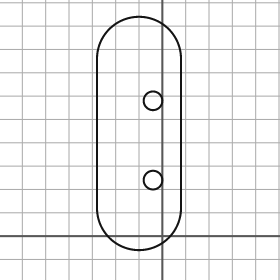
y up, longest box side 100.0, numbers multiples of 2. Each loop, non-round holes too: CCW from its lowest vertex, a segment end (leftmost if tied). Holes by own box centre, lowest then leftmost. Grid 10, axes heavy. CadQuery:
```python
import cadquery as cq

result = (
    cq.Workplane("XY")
    .moveTo(-28.0, 12.0)
    .threePointArc((-10.0, -6.0), (8.0, 12.0))
    .lineTo(8.0, 76.0)
    .threePointArc((-10.0, 94.0), (-28.0, 76.0))
    .close()
    .moveTo(-4.0, 24.0)
    .circle(4.0)
    .moveTo(-4.0, 58.0)
    .circle(4.0)
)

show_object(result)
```